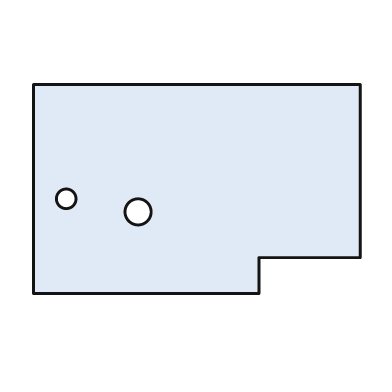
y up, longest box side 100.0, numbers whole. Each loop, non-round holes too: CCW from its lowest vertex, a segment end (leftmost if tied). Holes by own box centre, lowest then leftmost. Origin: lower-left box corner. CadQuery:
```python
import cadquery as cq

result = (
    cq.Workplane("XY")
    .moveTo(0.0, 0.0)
    .lineTo(69.0, 0.0)
    .lineTo(69.0, 11.0)
    .lineTo(100.0, 11.0)
    .lineTo(100.0, 64.0)
    .lineTo(0.0, 64.0)
    .close()
    .moveTo(32.0, 25.0)
    .circle(4.0)
    .moveTo(10.0, 29.0)
    .circle(3.0)
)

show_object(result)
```